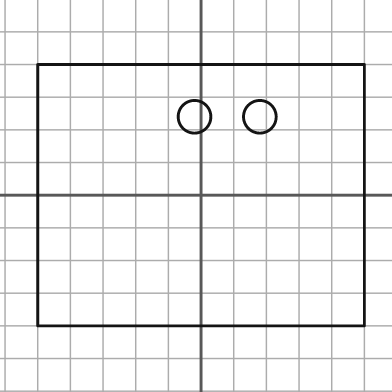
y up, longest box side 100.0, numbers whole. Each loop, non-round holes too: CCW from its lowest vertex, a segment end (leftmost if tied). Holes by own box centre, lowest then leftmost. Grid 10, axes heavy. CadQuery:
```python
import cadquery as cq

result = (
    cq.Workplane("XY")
    .moveTo(-50.0, -40.0)
    .lineTo(50.0, -40.0)
    .lineTo(50.0, 40.0)
    .lineTo(-50.0, 40.0)
    .close()
    .moveTo(-2.0, 24.0)
    .circle(5.0)
    .moveTo(18.0, 24.0)
    .circle(5.0)
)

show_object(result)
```